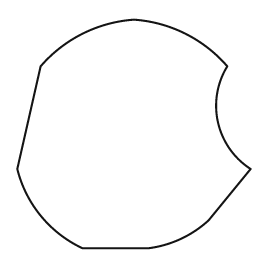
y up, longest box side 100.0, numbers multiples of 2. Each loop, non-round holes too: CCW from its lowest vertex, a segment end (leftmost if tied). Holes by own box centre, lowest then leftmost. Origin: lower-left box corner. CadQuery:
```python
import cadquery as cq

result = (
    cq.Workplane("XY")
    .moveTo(28.0, 0.0)
    .lineTo(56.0, 0.0)
    .threePointArc((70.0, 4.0), (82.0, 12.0))
    .lineTo(100.0, 34.0)
    .threePointArc((86.0, 54.0), (90.0, 78.0))
    .threePointArc((72.0, 92.0), (50.0, 98.0))
    .threePointArc((28.0, 92.0), (10.0, 78.0))
    .lineTo(0.0, 34.0)
    .threePointArc((10.0, 14.0), (28.0, 0.0))
    .close()
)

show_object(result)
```